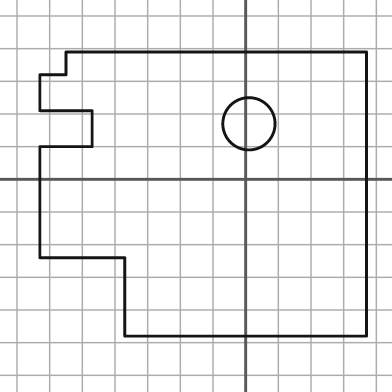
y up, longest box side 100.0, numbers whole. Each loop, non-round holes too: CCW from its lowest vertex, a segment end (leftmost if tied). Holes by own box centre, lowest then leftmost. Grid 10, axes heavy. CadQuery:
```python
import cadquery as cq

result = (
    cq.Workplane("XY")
    .moveTo(-37.0, -48.0)
    .lineTo(37.0, -48.0)
    .lineTo(37.0, 39.0)
    .lineTo(-55.0, 39.0)
    .lineTo(-55.0, 32.0)
    .lineTo(-63.0, 32.0)
    .lineTo(-63.0, 21.0)
    .lineTo(-47.0, 21.0)
    .lineTo(-47.0, 10.0)
    .lineTo(-63.0, 10.0)
    .lineTo(-63.0, -24.0)
    .lineTo(-37.0, -24.0)
    .close()
    .moveTo(1.0, 17.0)
    .circle(8.0)
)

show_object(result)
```